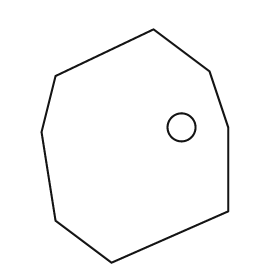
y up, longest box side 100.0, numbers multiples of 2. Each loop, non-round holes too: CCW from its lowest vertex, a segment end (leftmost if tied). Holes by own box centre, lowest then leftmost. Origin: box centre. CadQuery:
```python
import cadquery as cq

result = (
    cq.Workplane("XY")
    .moveTo(-10.0, -50.0)
    .lineTo(40.0, -28.0)
    .lineTo(40.0, 8.0)
    .lineTo(32.0, 32.0)
    .lineTo(8.0, 50.0)
    .lineTo(-34.0, 30.0)
    .lineTo(-40.0, 6.0)
    .lineTo(-34.0, -32.0)
    .close()
    .moveTo(20.0, 8.0)
    .circle(6.0)
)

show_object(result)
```